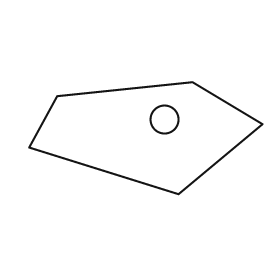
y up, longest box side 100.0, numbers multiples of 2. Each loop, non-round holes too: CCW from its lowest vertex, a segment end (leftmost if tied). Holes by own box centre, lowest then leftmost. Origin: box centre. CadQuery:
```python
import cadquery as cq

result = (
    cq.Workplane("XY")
    .moveTo(14.0, -24.0)
    .lineTo(50.0, 6.0)
    .lineTo(20.0, 24.0)
    .lineTo(-38.0, 18.0)
    .lineTo(-50.0, -4.0)
    .close()
    .moveTo(8.0, 8.0)
    .circle(6.0)
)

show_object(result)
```